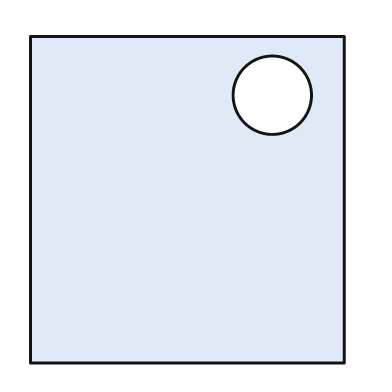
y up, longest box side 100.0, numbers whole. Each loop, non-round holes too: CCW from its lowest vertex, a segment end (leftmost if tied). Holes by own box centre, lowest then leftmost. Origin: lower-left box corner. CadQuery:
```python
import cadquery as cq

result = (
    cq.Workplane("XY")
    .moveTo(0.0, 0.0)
    .lineTo(96.0, 0.0)
    .lineTo(96.0, 100.0)
    .lineTo(0.0, 100.0)
    .close()
    .moveTo(74.0, 82.0)
    .circle(12.0)
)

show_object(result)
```